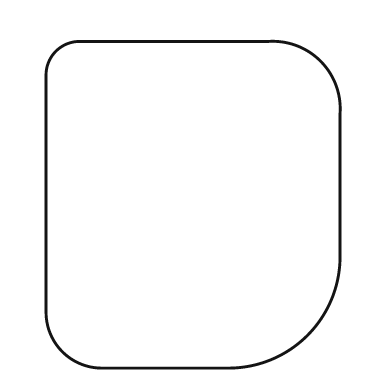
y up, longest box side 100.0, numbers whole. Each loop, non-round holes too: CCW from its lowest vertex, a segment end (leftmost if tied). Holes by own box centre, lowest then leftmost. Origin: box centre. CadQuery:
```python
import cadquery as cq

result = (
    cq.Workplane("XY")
    .moveTo(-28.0, -50.0)
    .lineTo(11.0, -50.0)
    .threePointArc((35.0, -40.0), (45.0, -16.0))
    .lineTo(45.0, 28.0)
    .threePointArc((39.0, 44.0), (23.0, 50.0))
    .lineTo(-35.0, 50.0)
    .threePointArc((-42.0, 47.0), (-45.0, 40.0))
    .lineTo(-45.0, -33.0)
    .threePointArc((-40.0, -45.0), (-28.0, -50.0))
    .close()
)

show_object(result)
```